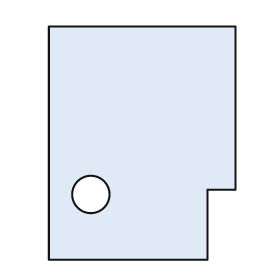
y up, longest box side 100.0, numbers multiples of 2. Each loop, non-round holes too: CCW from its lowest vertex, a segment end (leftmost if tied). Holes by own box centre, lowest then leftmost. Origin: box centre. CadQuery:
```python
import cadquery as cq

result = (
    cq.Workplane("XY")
    .moveTo(-40.0, -50.0)
    .lineTo(28.0, -50.0)
    .lineTo(28.0, -20.0)
    .lineTo(40.0, -20.0)
    .lineTo(40.0, 50.0)
    .lineTo(-40.0, 50.0)
    .close()
    .moveTo(-22.0, -22.0)
    .circle(8.0)
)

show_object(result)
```